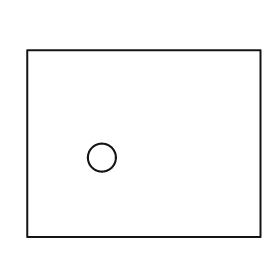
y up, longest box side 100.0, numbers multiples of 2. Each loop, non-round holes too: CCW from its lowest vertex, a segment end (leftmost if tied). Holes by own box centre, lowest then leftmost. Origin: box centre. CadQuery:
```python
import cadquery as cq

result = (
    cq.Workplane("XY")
    .moveTo(-50.0, -40.0)
    .lineTo(50.0, -40.0)
    .lineTo(50.0, 40.0)
    .lineTo(-50.0, 40.0)
    .close()
    .moveTo(-18.0, -6.0)
    .circle(6.0)
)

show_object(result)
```